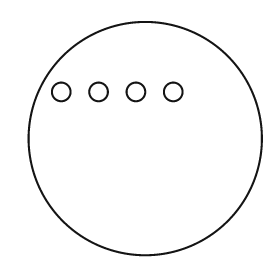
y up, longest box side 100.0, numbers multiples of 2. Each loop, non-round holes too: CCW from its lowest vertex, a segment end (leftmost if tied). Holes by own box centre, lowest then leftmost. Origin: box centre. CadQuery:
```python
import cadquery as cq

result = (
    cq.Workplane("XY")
    .moveTo(0.0, 0.0)
    .circle(50.0)
    .moveTo(-36.0, 20.0)
    .circle(4.0)
    .moveTo(-20.0, 20.0)
    .circle(4.0)
    .moveTo(-4.0, 20.0)
    .circle(4.0)
    .moveTo(12.0, 20.0)
    .circle(4.0)
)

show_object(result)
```